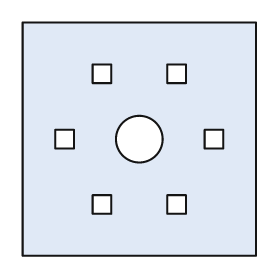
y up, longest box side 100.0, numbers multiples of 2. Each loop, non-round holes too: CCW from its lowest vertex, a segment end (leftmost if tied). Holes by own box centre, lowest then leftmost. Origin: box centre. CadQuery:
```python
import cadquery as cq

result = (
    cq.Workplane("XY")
    .moveTo(-50.0, -50.0)
    .lineTo(50.0, -50.0)
    .lineTo(50.0, 50.0)
    .lineTo(-50.0, 50.0)
    .close()
    .moveTo(-20.0, -32.0)
    .lineTo(-12.0, -32.0)
    .lineTo(-12.0, -24.0)
    .lineTo(-20.0, -24.0)
    .close()
    .moveTo(12.0, -32.0)
    .lineTo(20.0, -32.0)
    .lineTo(20.0, -24.0)
    .lineTo(12.0, -24.0)
    .close()
    .moveTo(-36.0, -4.0)
    .lineTo(-28.0, -4.0)
    .lineTo(-28.0, 4.0)
    .lineTo(-36.0, 4.0)
    .close()
    .moveTo(0.0, 0.0)
    .circle(10.0)
    .moveTo(28.0, -4.0)
    .lineTo(36.0, -4.0)
    .lineTo(36.0, 4.0)
    .lineTo(28.0, 4.0)
    .close()
    .moveTo(-20.0, 24.0)
    .lineTo(-12.0, 24.0)
    .lineTo(-12.0, 32.0)
    .lineTo(-20.0, 32.0)
    .close()
    .moveTo(12.0, 24.0)
    .lineTo(20.0, 24.0)
    .lineTo(20.0, 32.0)
    .lineTo(12.0, 32.0)
    .close()
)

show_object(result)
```